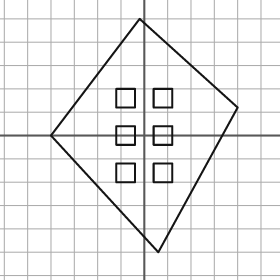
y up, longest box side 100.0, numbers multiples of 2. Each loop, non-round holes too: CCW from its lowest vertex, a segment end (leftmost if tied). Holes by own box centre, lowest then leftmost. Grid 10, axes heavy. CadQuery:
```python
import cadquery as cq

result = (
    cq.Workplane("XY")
    .moveTo(6.0, -50.0)
    .lineTo(40.0, 12.0)
    .lineTo(-2.0, 50.0)
    .lineTo(-40.0, 0.0)
    .close()
    .moveTo(-12.0, -20.0)
    .lineTo(-4.0, -20.0)
    .lineTo(-4.0, -12.0)
    .lineTo(-12.0, -12.0)
    .close()
    .moveTo(4.0, -20.0)
    .lineTo(12.0, -20.0)
    .lineTo(12.0, -12.0)
    .lineTo(4.0, -12.0)
    .close()
    .moveTo(-12.0, -4.0)
    .lineTo(-4.0, -4.0)
    .lineTo(-4.0, 4.0)
    .lineTo(-12.0, 4.0)
    .close()
    .moveTo(4.0, -4.0)
    .lineTo(12.0, -4.0)
    .lineTo(12.0, 4.0)
    .lineTo(4.0, 4.0)
    .close()
    .moveTo(-12.0, 12.0)
    .lineTo(-4.0, 12.0)
    .lineTo(-4.0, 20.0)
    .lineTo(-12.0, 20.0)
    .close()
    .moveTo(4.0, 12.0)
    .lineTo(12.0, 12.0)
    .lineTo(12.0, 20.0)
    .lineTo(4.0, 20.0)
    .close()
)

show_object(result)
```